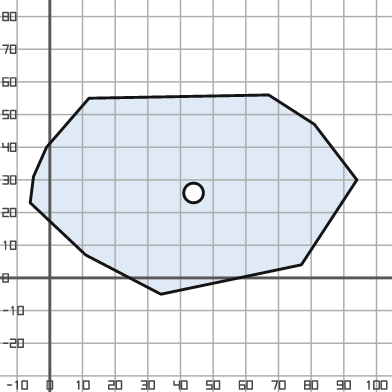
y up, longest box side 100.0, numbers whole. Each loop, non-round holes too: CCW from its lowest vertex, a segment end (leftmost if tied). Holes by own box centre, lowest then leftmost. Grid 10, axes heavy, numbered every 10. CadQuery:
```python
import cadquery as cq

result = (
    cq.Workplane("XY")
    .moveTo(34.0, -5.0)
    .lineTo(77.0, 4.0)
    .lineTo(94.0, 30.0)
    .lineTo(81.0, 47.0)
    .lineTo(67.0, 56.0)
    .lineTo(12.0, 55.0)
    .lineTo(-1.0, 40.0)
    .lineTo(-5.0, 31.0)
    .lineTo(-6.0, 23.0)
    .lineTo(11.0, 7.0)
    .close()
    .moveTo(44.0, 26.0)
    .circle(3.0)
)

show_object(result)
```